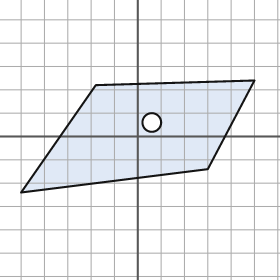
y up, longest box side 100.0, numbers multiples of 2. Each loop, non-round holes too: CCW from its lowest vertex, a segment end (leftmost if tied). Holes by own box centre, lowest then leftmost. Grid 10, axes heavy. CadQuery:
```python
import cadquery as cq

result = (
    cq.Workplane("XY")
    .moveTo(-50.0, -24.0)
    .lineTo(30.0, -14.0)
    .lineTo(50.0, 24.0)
    .lineTo(-18.0, 22.0)
    .close()
    .moveTo(6.0, 6.0)
    .circle(4.0)
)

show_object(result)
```